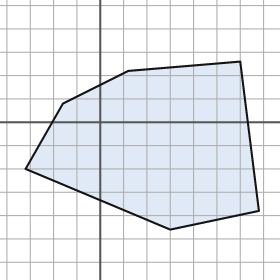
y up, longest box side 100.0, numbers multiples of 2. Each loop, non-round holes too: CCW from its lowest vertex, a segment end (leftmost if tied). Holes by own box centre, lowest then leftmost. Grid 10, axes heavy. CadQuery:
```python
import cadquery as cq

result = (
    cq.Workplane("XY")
    .moveTo(30.0, -46.0)
    .lineTo(68.0, -38.0)
    .lineTo(60.0, 26.0)
    .lineTo(12.0, 22.0)
    .lineTo(-16.0, 8.0)
    .lineTo(-32.0, -20.0)
    .close()
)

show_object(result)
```